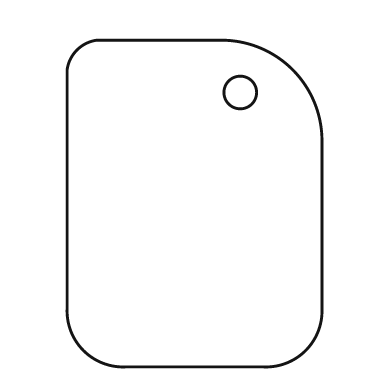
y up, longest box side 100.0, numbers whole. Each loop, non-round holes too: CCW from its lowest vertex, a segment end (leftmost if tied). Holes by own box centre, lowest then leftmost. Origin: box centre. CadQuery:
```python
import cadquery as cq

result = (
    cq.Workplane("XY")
    .moveTo(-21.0, -50.0)
    .lineTo(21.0, -50.0)
    .threePointArc((34.0, -45.0), (39.0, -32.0))
    .lineTo(39.0, 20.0)
    .threePointArc((30.0, 41.0), (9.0, 50.0))
    .lineTo(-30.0, 50.0)
    .threePointArc((-36.0, 47.0), (-39.0, 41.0))
    .lineTo(-39.0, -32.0)
    .threePointArc((-34.0, -45.0), (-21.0, -50.0))
    .close()
    .moveTo(14.0, 34.0)
    .circle(5.0)
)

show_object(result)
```